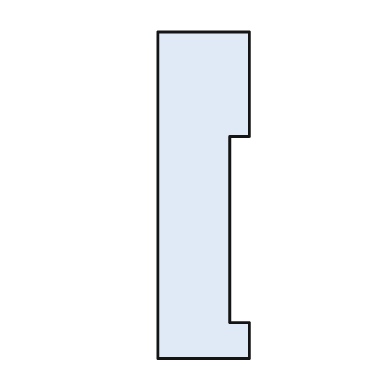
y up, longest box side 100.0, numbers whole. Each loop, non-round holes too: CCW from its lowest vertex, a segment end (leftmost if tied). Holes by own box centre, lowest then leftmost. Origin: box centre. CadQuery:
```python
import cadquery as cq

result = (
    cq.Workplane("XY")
    .moveTo(-14.0, -50.0)
    .lineTo(14.0, -50.0)
    .lineTo(14.0, -39.0)
    .lineTo(8.0, -39.0)
    .lineTo(8.0, 18.0)
    .lineTo(14.0, 18.0)
    .lineTo(14.0, 50.0)
    .lineTo(-14.0, 50.0)
    .close()
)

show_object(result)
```